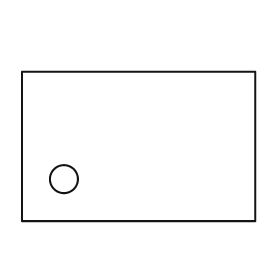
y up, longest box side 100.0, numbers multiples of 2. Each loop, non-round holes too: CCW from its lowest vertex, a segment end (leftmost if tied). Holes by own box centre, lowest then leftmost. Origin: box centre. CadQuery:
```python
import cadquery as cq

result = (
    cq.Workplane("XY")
    .moveTo(-50.0, -32.0)
    .lineTo(50.0, -32.0)
    .lineTo(50.0, 32.0)
    .lineTo(-50.0, 32.0)
    .close()
    .moveTo(-32.0, -14.0)
    .circle(6.0)
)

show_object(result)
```